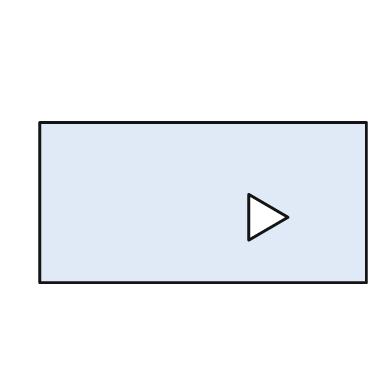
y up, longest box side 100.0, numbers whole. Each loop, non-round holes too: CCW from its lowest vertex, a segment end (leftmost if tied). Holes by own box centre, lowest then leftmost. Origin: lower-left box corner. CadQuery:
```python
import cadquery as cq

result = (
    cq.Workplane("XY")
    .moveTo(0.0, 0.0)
    .lineTo(100.0, 0.0)
    .lineTo(100.0, 49.0)
    .lineTo(0.0, 49.0)
    .close()
    .moveTo(64.0, 13.0)
    .lineTo(76.0, 20.0)
    .lineTo(64.0, 27.0)
    .close()
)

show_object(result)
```